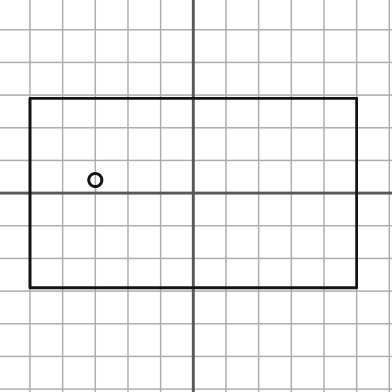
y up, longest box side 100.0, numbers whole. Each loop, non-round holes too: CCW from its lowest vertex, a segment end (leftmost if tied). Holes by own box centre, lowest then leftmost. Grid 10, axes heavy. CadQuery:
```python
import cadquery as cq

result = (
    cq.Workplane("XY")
    .moveTo(-50.0, -29.0)
    .lineTo(50.0, -29.0)
    .lineTo(50.0, 29.0)
    .lineTo(-50.0, 29.0)
    .close()
    .moveTo(-30.0, 4.0)
    .circle(2.0)
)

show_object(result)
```